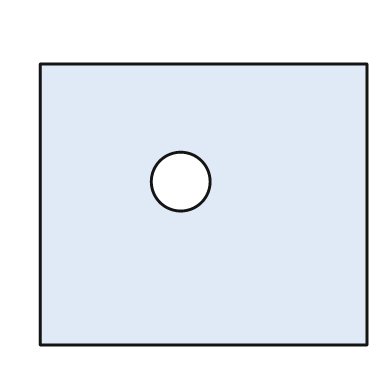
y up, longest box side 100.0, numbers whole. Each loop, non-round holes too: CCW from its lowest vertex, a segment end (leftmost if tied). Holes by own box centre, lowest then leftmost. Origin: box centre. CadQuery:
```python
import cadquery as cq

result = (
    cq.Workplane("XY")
    .moveTo(-50.0, -43.0)
    .lineTo(50.0, -43.0)
    .lineTo(50.0, 43.0)
    .lineTo(-50.0, 43.0)
    .close()
    .moveTo(-7.0, 7.0)
    .circle(9.0)
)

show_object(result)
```